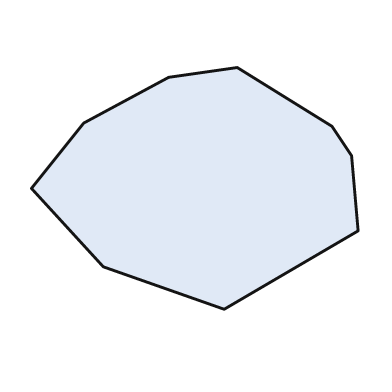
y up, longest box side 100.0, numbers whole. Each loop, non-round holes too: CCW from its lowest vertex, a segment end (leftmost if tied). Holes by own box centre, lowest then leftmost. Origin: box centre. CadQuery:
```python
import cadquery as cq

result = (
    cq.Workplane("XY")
    .moveTo(9.0, -37.0)
    .lineTo(50.0, -13.0)
    .lineTo(48.0, 10.0)
    .lineTo(42.0, 19.0)
    .lineTo(13.0, 37.0)
    .lineTo(-8.0, 34.0)
    .lineTo(-34.0, 20.0)
    .lineTo(-50.0, 0.0)
    .lineTo(-28.0, -24.0)
    .close()
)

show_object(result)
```